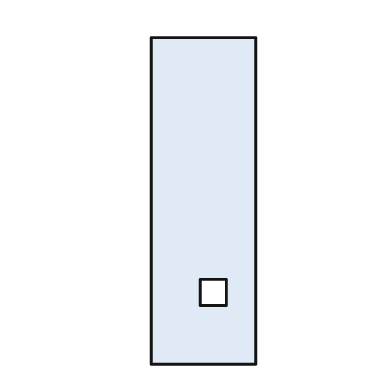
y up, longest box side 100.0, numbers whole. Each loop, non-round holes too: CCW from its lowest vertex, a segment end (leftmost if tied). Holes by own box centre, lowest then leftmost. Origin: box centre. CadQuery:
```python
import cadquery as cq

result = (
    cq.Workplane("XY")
    .moveTo(-16.0, -50.0)
    .lineTo(16.0, -50.0)
    .lineTo(16.0, 50.0)
    .lineTo(-16.0, 50.0)
    .close()
    .moveTo(-1.0, -32.0)
    .lineTo(7.0, -32.0)
    .lineTo(7.0, -24.0)
    .lineTo(-1.0, -24.0)
    .close()
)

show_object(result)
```